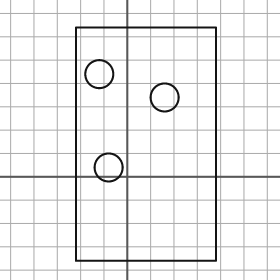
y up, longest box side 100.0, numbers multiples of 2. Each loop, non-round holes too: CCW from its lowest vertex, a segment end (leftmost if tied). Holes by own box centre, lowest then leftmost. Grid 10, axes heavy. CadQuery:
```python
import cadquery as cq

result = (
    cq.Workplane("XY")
    .moveTo(-22.0, -36.0)
    .lineTo(38.0, -36.0)
    .lineTo(38.0, 64.0)
    .lineTo(-22.0, 64.0)
    .close()
    .moveTo(-8.0, 4.0)
    .circle(6.0)
    .moveTo(16.0, 34.0)
    .circle(6.0)
    .moveTo(-12.0, 44.0)
    .circle(6.0)
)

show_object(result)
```